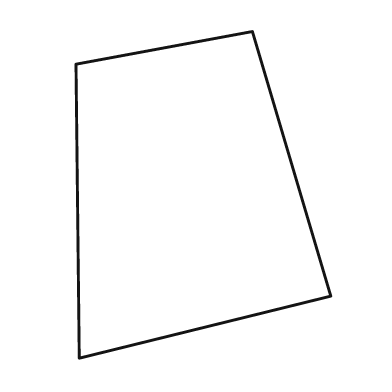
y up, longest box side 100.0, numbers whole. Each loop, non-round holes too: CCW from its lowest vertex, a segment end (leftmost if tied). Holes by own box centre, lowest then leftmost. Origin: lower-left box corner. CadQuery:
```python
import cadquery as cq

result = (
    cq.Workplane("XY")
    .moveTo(1.0, 0.0)
    .lineTo(78.0, 19.0)
    .lineTo(54.0, 100.0)
    .lineTo(0.0, 90.0)
    .close()
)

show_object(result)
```